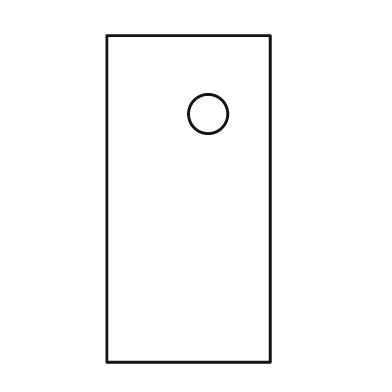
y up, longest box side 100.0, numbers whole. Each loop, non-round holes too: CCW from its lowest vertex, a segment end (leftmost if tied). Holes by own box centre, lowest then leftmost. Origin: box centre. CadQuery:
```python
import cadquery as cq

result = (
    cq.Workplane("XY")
    .moveTo(-25.0, -50.0)
    .lineTo(25.0, -50.0)
    .lineTo(25.0, 50.0)
    .lineTo(-25.0, 50.0)
    .close()
    .moveTo(6.0, 26.0)
    .circle(6.0)
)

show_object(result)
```